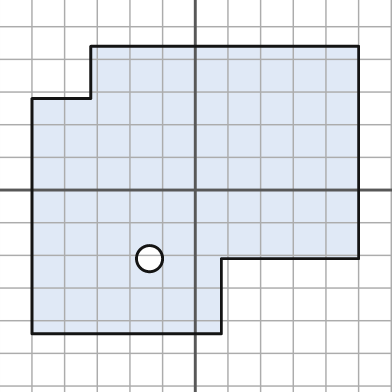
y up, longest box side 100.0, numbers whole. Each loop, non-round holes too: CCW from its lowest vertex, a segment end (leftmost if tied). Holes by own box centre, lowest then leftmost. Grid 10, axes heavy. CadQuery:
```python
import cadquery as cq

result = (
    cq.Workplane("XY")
    .moveTo(-50.0, -44.0)
    .lineTo(8.0, -44.0)
    .lineTo(8.0, -21.0)
    .lineTo(50.0, -21.0)
    .lineTo(50.0, 44.0)
    .lineTo(-32.0, 44.0)
    .lineTo(-32.0, 28.0)
    .lineTo(-50.0, 28.0)
    .close()
    .moveTo(-14.0, -21.0)
    .circle(4.0)
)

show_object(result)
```